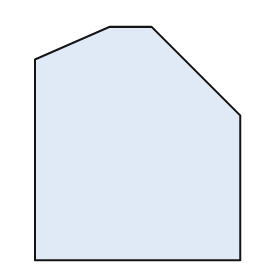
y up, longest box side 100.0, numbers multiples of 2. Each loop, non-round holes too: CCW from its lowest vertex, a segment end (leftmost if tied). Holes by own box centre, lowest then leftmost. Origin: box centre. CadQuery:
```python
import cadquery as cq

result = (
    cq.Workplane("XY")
    .moveTo(-44.0, -50.0)
    .lineTo(44.0, -50.0)
    .lineTo(44.0, 12.0)
    .lineTo(6.0, 50.0)
    .lineTo(-12.0, 50.0)
    .lineTo(-44.0, 36.0)
    .close()
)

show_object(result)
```